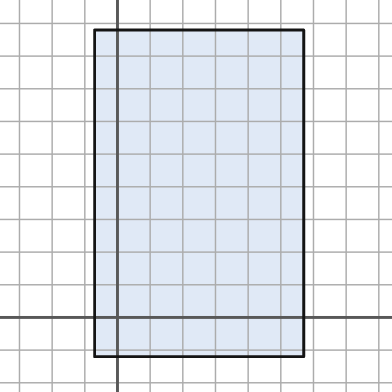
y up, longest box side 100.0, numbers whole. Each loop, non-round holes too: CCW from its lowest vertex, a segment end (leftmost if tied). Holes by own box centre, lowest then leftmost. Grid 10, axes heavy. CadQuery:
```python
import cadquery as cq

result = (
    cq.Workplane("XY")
    .moveTo(-7.0, -12.0)
    .lineTo(57.0, -12.0)
    .lineTo(57.0, 88.0)
    .lineTo(-7.0, 88.0)
    .close()
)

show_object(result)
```